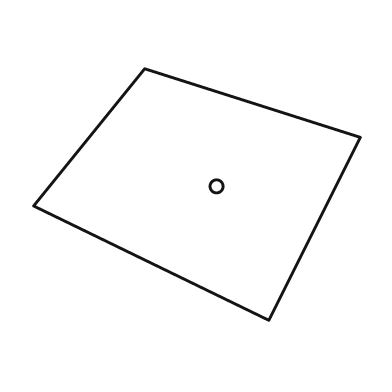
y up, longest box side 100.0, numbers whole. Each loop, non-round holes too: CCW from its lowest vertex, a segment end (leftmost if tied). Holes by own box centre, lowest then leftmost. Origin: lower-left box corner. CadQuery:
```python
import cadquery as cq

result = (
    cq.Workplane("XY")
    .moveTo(72.0, 0.0)
    .lineTo(100.0, 56.0)
    .lineTo(34.0, 77.0)
    .lineTo(0.0, 35.0)
    .close()
    .moveTo(56.0, 41.0)
    .circle(2.0)
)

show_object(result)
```